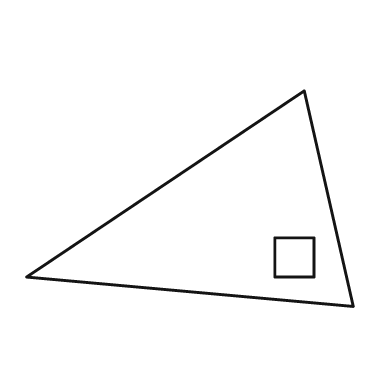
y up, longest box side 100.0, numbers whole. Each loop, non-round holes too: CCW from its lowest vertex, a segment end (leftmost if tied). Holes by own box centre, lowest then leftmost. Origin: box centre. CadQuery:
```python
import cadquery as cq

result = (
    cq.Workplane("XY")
    .moveTo(50.0, -33.0)
    .lineTo(35.0, 33.0)
    .lineTo(-50.0, -24.0)
    .close()
    .moveTo(26.0, -24.0)
    .lineTo(38.0, -24.0)
    .lineTo(38.0, -12.0)
    .lineTo(26.0, -12.0)
    .close()
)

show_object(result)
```